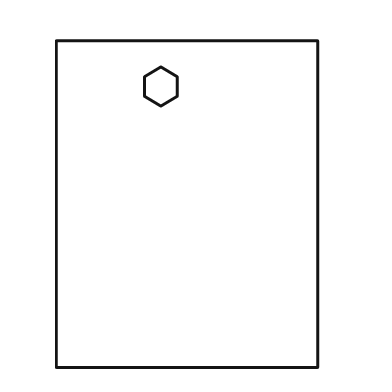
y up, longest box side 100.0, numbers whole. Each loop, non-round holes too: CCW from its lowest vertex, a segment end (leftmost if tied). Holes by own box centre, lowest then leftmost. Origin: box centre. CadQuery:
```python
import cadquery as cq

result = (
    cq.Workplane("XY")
    .moveTo(-40.0, -50.0)
    .lineTo(40.0, -50.0)
    .lineTo(40.0, 50.0)
    .lineTo(-40.0, 50.0)
    .close()
    .moveTo(-8.0, 30.0)
    .lineTo(-3.0, 33.0)
    .lineTo(-3.0, 39.0)
    .lineTo(-8.0, 42.0)
    .lineTo(-13.0, 39.0)
    .lineTo(-13.0, 33.0)
    .close()
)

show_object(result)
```